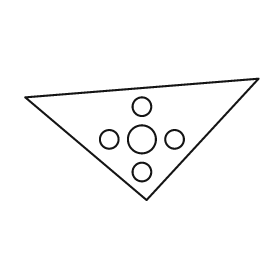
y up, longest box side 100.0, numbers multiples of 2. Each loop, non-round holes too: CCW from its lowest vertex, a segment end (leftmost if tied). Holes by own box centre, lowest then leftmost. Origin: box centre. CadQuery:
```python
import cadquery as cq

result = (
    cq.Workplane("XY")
    .moveTo(2.0, -26.0)
    .lineTo(50.0, 26.0)
    .lineTo(-50.0, 18.0)
    .close()
    .moveTo(0.0, -14.0)
    .circle(4.0)
    .moveTo(-14.0, 0.0)
    .circle(4.0)
    .moveTo(0.0, 0.0)
    .circle(6.0)
    .moveTo(14.0, 0.0)
    .circle(4.0)
    .moveTo(0.0, 14.0)
    .circle(4.0)
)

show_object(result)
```